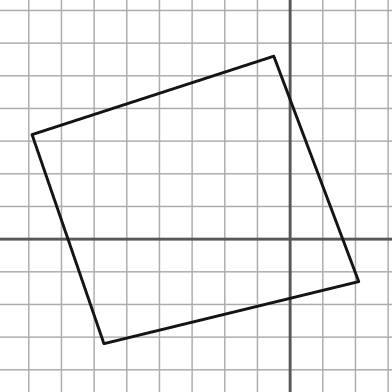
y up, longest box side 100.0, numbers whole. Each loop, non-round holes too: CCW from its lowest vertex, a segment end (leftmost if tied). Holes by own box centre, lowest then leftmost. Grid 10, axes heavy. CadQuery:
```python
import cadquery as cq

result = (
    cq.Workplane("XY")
    .moveTo(-57.0, -32.0)
    .lineTo(21.0, -13.0)
    .lineTo(-5.0, 56.0)
    .lineTo(-79.0, 32.0)
    .close()
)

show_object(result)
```